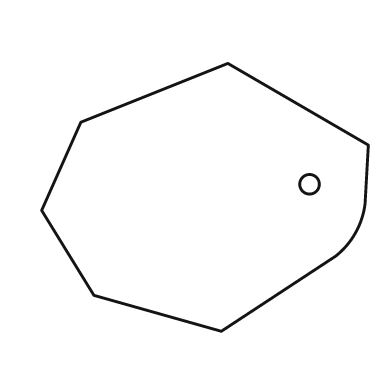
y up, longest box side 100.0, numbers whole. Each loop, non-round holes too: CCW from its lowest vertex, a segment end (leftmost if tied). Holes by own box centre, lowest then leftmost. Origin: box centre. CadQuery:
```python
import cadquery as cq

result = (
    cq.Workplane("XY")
    .moveTo(5.0, -41.0)
    .lineTo(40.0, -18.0)
    .threePointArc((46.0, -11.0), (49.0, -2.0))
    .lineTo(50.0, 16.0)
    .lineTo(7.0, 41.0)
    .lineTo(-38.0, 23.0)
    .lineTo(-50.0, -4.0)
    .lineTo(-34.0, -30.0)
    .close()
    .moveTo(32.0, 4.0)
    .circle(3.0)
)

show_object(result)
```